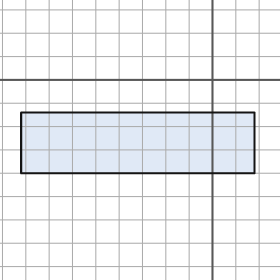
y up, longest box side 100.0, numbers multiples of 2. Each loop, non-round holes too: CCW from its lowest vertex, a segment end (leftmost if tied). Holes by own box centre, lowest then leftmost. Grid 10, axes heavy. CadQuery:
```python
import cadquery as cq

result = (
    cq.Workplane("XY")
    .moveTo(-82.0, -40.0)
    .lineTo(18.0, -40.0)
    .lineTo(18.0, -14.0)
    .lineTo(-82.0, -14.0)
    .close()
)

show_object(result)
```